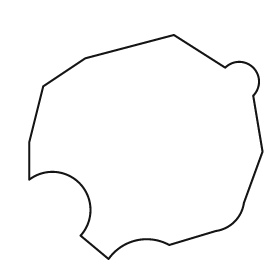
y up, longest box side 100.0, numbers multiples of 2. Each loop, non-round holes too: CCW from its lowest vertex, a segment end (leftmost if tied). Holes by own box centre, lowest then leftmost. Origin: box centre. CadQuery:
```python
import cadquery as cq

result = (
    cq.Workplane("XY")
    .moveTo(-16.0, -48.0)
    .threePointArc((-4.0, -40.0), (10.0, -42.0))
    .lineTo(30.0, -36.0)
    .threePointArc((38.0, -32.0), (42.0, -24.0))
    .lineTo(50.0, -2.0)
    .lineTo(46.0, 22.0)
    .threePointArc((46.0, 34.0), (34.0, 34.0))
    .lineTo(12.0, 48.0)
    .lineTo(-26.0, 38.0)
    .lineTo(-44.0, 26.0)
    .lineTo(-50.0, 2.0)
    .lineTo(-50.0, -14.0)
    .threePointArc((-28.0, -16.0), (-28.0, -38.0))
    .close()
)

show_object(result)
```